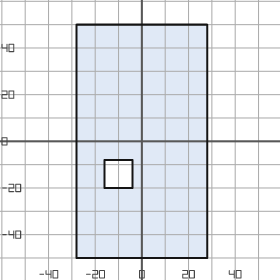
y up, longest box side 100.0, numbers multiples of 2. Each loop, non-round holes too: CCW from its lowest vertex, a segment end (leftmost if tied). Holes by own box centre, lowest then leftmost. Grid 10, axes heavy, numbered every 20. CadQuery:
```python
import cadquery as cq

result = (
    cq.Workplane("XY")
    .moveTo(-28.0, -50.0)
    .lineTo(28.0, -50.0)
    .lineTo(28.0, 50.0)
    .lineTo(-28.0, 50.0)
    .close()
    .moveTo(-16.0, -20.0)
    .lineTo(-4.0, -20.0)
    .lineTo(-4.0, -8.0)
    .lineTo(-16.0, -8.0)
    .close()
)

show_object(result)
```